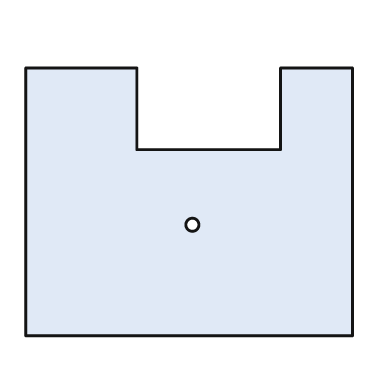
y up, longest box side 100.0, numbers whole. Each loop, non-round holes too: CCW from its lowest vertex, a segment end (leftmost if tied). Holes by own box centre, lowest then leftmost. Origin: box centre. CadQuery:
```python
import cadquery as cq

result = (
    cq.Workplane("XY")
    .moveTo(-50.0, -41.0)
    .lineTo(50.0, -41.0)
    .lineTo(50.0, 41.0)
    .lineTo(28.0, 41.0)
    .lineTo(28.0, 16.0)
    .lineTo(-16.0, 16.0)
    .lineTo(-16.0, 41.0)
    .lineTo(-50.0, 41.0)
    .close()
    .moveTo(1.0, -7.0)
    .circle(2.0)
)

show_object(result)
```